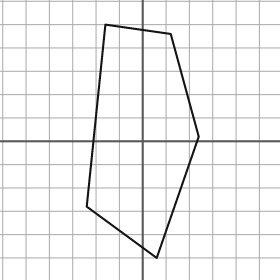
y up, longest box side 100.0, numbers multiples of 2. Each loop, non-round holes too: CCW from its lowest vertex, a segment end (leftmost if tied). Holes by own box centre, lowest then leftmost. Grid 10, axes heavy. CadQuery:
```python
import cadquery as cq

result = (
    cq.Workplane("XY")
    .moveTo(6.0, -50.0)
    .lineTo(24.0, 2.0)
    .lineTo(12.0, 46.0)
    .lineTo(-16.0, 50.0)
    .lineTo(-24.0, -28.0)
    .close()
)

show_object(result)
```